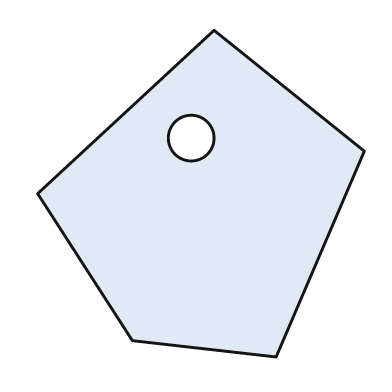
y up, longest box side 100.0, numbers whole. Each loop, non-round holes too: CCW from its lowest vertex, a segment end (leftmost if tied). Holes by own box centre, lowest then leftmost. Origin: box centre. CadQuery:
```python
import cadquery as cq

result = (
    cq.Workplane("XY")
    .moveTo(23.0, -50.0)
    .lineTo(50.0, 13.0)
    .lineTo(4.0, 50.0)
    .lineTo(-50.0, 0.0)
    .lineTo(-21.0, -45.0)
    .close()
    .moveTo(-3.0, 17.0)
    .circle(7.0)
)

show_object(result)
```